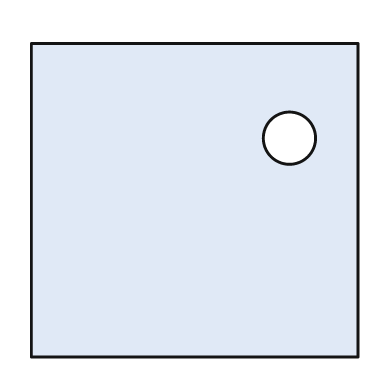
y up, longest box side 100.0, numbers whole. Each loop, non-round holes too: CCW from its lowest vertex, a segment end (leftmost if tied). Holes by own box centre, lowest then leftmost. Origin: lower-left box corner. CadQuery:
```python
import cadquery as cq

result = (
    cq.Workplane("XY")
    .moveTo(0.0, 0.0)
    .lineTo(100.0, 0.0)
    .lineTo(100.0, 96.0)
    .lineTo(0.0, 96.0)
    .close()
    .moveTo(79.0, 67.0)
    .circle(8.0)
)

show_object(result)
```